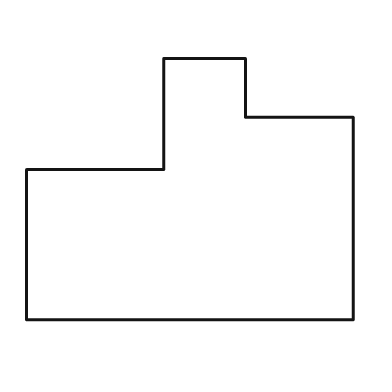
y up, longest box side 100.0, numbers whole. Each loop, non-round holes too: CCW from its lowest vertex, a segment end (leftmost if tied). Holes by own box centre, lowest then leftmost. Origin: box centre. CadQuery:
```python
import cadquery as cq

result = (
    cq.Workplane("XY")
    .moveTo(-50.0, -40.0)
    .lineTo(50.0, -40.0)
    .lineTo(50.0, 22.0)
    .lineTo(17.0, 22.0)
    .lineTo(17.0, 40.0)
    .lineTo(-8.0, 40.0)
    .lineTo(-8.0, 6.0)
    .lineTo(-50.0, 6.0)
    .close()
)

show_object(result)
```